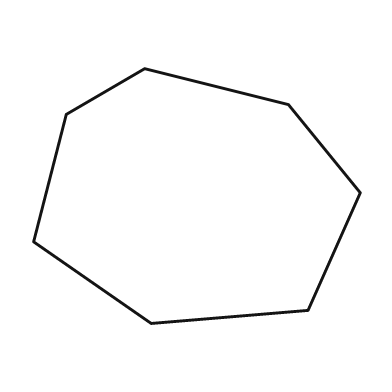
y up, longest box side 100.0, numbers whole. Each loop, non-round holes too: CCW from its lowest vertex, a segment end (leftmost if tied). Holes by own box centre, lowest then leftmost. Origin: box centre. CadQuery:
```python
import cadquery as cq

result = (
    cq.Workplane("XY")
    .moveTo(-14.0, -39.0)
    .lineTo(34.0, -35.0)
    .lineTo(50.0, 1.0)
    .lineTo(28.0, 28.0)
    .lineTo(-16.0, 39.0)
    .lineTo(-40.0, 25.0)
    .lineTo(-50.0, -14.0)
    .close()
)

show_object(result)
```